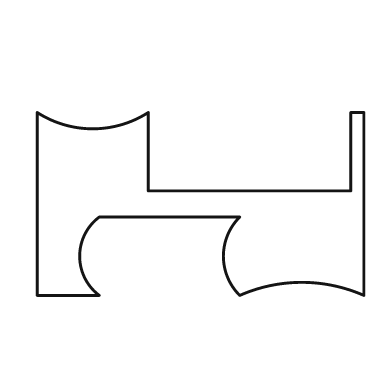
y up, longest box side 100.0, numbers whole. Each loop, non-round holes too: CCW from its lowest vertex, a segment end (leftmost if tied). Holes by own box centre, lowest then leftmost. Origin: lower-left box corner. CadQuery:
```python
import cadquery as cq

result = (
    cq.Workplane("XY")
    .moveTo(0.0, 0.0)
    .lineTo(19.0, 0.0)
    .threePointArc((13.0, 12.0), (19.0, 24.0))
    .lineTo(62.0, 24.0)
    .threePointArc((57.0, 12.0), (62.0, 0.0))
    .threePointArc((81.0, 4.0), (100.0, 0.0))
    .lineTo(100.0, 56.0)
    .lineTo(96.0, 56.0)
    .lineTo(96.0, 32.0)
    .lineTo(34.0, 32.0)
    .lineTo(34.0, 56.0)
    .threePointArc((17.0, 51.0), (0.0, 56.0))
    .close()
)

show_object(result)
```